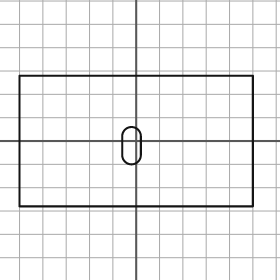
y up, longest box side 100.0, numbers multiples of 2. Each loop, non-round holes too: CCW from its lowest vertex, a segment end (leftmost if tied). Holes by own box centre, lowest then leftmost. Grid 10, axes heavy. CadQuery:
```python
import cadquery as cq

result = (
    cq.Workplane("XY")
    .moveTo(-50.0, -28.0)
    .lineTo(50.0, -28.0)
    .lineTo(50.0, 28.0)
    .lineTo(-50.0, 28.0)
    .close()
    .moveTo(-6.0, -6.0)
    .threePointArc((-2.0, -10.0), (2.0, -6.0))
    .lineTo(2.0, 2.0)
    .threePointArc((-2.0, 6.0), (-6.0, 2.0))
    .close()
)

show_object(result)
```